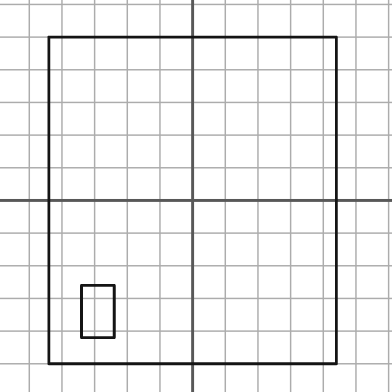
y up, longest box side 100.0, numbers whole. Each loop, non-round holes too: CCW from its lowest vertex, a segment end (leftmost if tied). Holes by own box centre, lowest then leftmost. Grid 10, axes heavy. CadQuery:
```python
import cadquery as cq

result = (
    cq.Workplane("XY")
    .moveTo(-44.0, -50.0)
    .lineTo(44.0, -50.0)
    .lineTo(44.0, 50.0)
    .lineTo(-44.0, 50.0)
    .close()
    .moveTo(-34.0, -42.0)
    .lineTo(-24.0, -42.0)
    .lineTo(-24.0, -26.0)
    .lineTo(-34.0, -26.0)
    .close()
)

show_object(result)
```